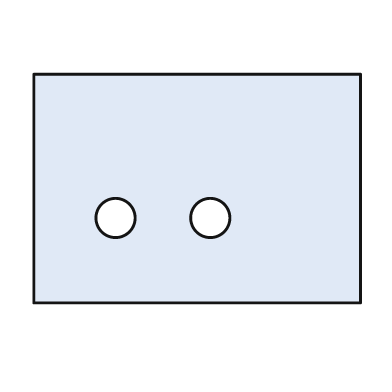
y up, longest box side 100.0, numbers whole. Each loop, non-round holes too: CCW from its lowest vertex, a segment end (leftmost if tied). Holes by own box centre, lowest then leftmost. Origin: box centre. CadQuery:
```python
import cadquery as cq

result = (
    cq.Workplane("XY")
    .moveTo(-50.0, -35.0)
    .lineTo(50.0, -35.0)
    .lineTo(50.0, 35.0)
    .lineTo(-50.0, 35.0)
    .close()
    .moveTo(-25.0, -9.0)
    .circle(6.0)
    .moveTo(4.0, -9.0)
    .circle(6.0)
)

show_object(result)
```